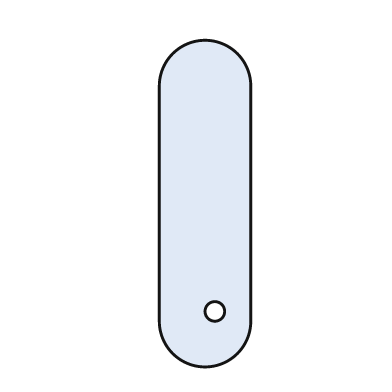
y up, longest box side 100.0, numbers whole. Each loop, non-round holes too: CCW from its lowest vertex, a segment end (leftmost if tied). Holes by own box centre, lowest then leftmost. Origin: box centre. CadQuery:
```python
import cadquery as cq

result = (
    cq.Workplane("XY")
    .moveTo(-14.0, -36.0)
    .threePointArc((0.0, -50.0), (14.0, -36.0))
    .lineTo(14.0, 36.0)
    .threePointArc((0.0, 50.0), (-14.0, 36.0))
    .close()
    .moveTo(3.0, -33.0)
    .circle(3.0)
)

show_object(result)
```